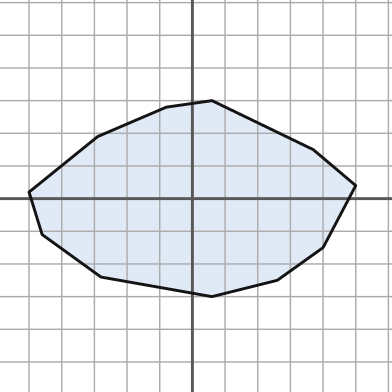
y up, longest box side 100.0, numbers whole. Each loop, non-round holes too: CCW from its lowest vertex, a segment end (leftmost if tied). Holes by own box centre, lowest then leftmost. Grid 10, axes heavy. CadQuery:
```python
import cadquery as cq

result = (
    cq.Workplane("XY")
    .moveTo(6.0, -30.0)
    .lineTo(26.0, -25.0)
    .lineTo(40.0, -15.0)
    .lineTo(50.0, 4.0)
    .lineTo(37.0, 15.0)
    .lineTo(6.0, 30.0)
    .lineTo(-8.0, 28.0)
    .lineTo(-29.0, 19.0)
    .lineTo(-50.0, 2.0)
    .lineTo(-46.0, -11.0)
    .lineTo(-28.0, -24.0)
    .close()
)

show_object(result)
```